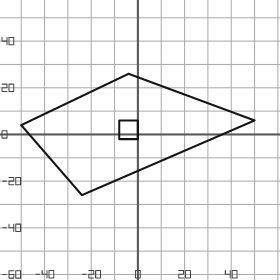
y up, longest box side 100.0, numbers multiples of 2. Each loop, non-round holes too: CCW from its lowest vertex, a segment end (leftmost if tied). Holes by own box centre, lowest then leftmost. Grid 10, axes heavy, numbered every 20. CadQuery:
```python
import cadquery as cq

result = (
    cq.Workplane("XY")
    .moveTo(-24.0, -26.0)
    .lineTo(50.0, 6.0)
    .lineTo(-4.0, 26.0)
    .lineTo(-50.0, 4.0)
    .close()
    .moveTo(-8.0, -2.0)
    .lineTo(0.0, -2.0)
    .lineTo(0.0, 6.0)
    .lineTo(-8.0, 6.0)
    .close()
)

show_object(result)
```